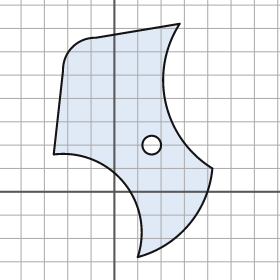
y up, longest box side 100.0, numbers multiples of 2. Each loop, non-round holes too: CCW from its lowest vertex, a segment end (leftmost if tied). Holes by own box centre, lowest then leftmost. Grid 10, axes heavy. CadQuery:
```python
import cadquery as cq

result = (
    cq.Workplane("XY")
    .moveTo(10.0, -28.0)
    .threePointArc((32.0, -14.0), (42.0, 10.0))
    .threePointArc((22.0, 38.0), (28.0, 72.0))
    .lineTo(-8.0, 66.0)
    .threePointArc((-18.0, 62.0), (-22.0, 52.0))
    .lineTo(-26.0, 16.0)
    .threePointArc((4.0, 4.0), (10.0, -28.0))
    .close()
    .moveTo(16.0, 20.0)
    .circle(4.0)
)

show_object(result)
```